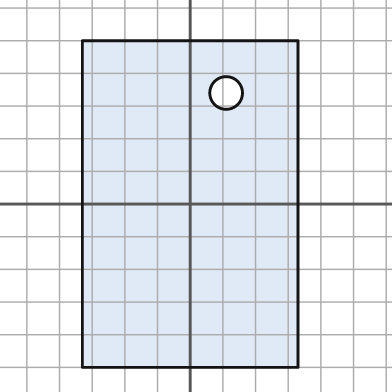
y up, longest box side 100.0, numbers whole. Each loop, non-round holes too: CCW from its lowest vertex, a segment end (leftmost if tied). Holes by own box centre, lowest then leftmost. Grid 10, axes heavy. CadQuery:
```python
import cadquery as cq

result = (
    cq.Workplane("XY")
    .moveTo(-33.0, -50.0)
    .lineTo(33.0, -50.0)
    .lineTo(33.0, 50.0)
    .lineTo(-33.0, 50.0)
    .close()
    .moveTo(11.0, 34.0)
    .circle(5.0)
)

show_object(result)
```